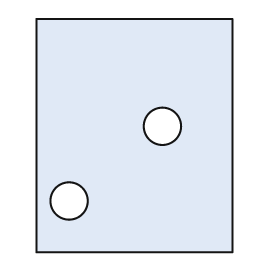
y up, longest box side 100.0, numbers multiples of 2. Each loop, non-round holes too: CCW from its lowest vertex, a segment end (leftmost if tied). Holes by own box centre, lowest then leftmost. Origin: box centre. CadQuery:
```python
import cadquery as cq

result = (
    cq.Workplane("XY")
    .moveTo(-42.0, -50.0)
    .lineTo(42.0, -50.0)
    .lineTo(42.0, 50.0)
    .lineTo(-42.0, 50.0)
    .close()
    .moveTo(-28.0, -28.0)
    .circle(8.0)
    .moveTo(12.0, 4.0)
    .circle(8.0)
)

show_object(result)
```